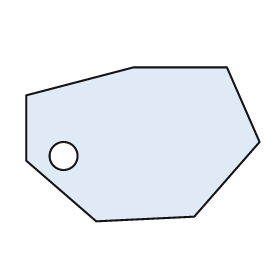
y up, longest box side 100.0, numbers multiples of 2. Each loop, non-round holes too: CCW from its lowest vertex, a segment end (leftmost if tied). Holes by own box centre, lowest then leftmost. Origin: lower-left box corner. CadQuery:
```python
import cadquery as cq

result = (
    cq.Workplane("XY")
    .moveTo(30.0, 0.0)
    .lineTo(72.0, 2.0)
    .lineTo(100.0, 34.0)
    .lineTo(86.0, 66.0)
    .lineTo(46.0, 66.0)
    .lineTo(0.0, 54.0)
    .lineTo(0.0, 26.0)
    .close()
    .moveTo(16.0, 28.0)
    .circle(6.0)
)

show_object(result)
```